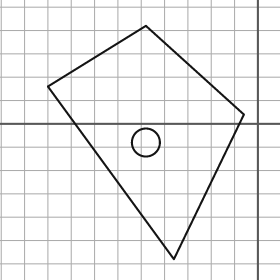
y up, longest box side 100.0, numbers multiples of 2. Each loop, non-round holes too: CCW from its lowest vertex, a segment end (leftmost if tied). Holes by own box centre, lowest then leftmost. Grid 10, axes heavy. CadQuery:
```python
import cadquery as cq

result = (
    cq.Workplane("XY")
    .moveTo(-36.0, -58.0)
    .lineTo(-6.0, 4.0)
    .lineTo(-48.0, 42.0)
    .lineTo(-90.0, 16.0)
    .close()
    .moveTo(-48.0, -8.0)
    .circle(6.0)
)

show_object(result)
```